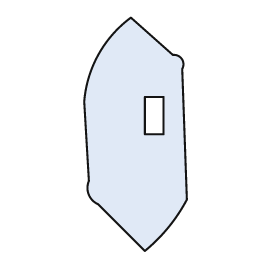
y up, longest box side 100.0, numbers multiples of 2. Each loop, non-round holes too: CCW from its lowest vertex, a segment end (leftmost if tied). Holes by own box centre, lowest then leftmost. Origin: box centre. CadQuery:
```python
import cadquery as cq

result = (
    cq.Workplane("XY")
    .moveTo(4.0, -50.0)
    .threePointArc((14.0, -40.0), (22.0, -28.0))
    .lineTo(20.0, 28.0)
    .threePointArc((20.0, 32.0), (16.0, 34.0))
    .lineTo(-2.0, 50.0)
    .threePointArc((-16.0, 34.0), (-22.0, 14.0))
    .lineTo(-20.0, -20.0)
    .threePointArc((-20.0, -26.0), (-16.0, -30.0))
    .close()
    .moveTo(4.0, 0.0)
    .lineTo(12.0, 0.0)
    .lineTo(12.0, 16.0)
    .lineTo(4.0, 16.0)
    .close()
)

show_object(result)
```